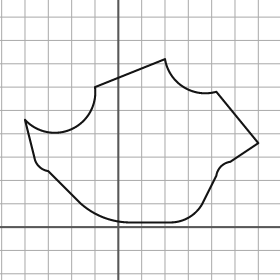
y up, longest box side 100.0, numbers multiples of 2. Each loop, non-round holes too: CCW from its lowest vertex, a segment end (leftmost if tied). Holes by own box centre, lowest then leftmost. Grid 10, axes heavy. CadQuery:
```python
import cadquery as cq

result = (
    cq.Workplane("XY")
    .moveTo(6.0, 2.0)
    .lineTo(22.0, 2.0)
    .threePointArc((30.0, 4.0), (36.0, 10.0))
    .lineTo(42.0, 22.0)
    .threePointArc((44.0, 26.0), (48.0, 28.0))
    .lineTo(60.0, 36.0)
    .lineTo(42.0, 58.0)
    .threePointArc((28.0, 60.0), (20.0, 72.0))
    .lineTo(-10.0, 60.0)
    .threePointArc((-20.0, 42.0), (-40.0, 46.0))
    .lineTo(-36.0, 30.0)
    .threePointArc((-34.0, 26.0), (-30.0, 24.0))
    .lineTo(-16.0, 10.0)
    .threePointArc((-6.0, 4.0), (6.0, 2.0))
    .close()
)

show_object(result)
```